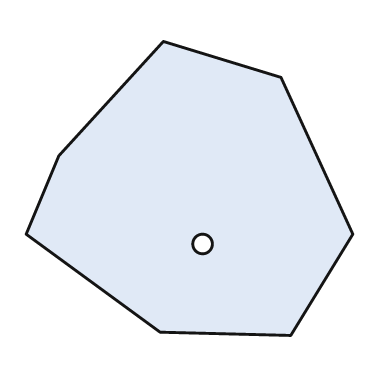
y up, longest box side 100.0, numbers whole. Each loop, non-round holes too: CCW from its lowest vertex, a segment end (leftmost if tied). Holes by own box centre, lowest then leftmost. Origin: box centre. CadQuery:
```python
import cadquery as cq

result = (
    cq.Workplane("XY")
    .moveTo(31.0, -45.0)
    .lineTo(50.0, -14.0)
    .lineTo(28.0, 34.0)
    .lineTo(-8.0, 45.0)
    .lineTo(-40.0, 10.0)
    .lineTo(-50.0, -14.0)
    .lineTo(-9.0, -44.0)
    .close()
    .moveTo(4.0, -17.0)
    .circle(3.0)
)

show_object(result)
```